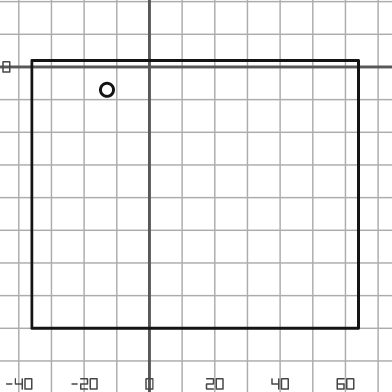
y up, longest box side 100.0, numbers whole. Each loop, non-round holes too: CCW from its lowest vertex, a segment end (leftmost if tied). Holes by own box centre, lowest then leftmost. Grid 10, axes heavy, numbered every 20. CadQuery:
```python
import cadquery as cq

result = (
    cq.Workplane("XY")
    .moveTo(-36.0, -80.0)
    .lineTo(64.0, -80.0)
    .lineTo(64.0, 2.0)
    .lineTo(-36.0, 2.0)
    .close()
    .moveTo(-13.0, -7.0)
    .circle(2.0)
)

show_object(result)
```